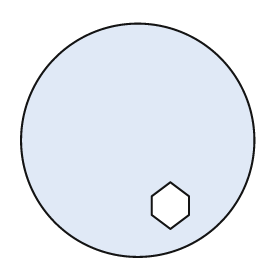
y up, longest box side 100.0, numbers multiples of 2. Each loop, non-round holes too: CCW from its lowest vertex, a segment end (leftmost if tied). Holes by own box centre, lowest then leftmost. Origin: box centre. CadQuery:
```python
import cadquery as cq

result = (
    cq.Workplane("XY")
    .moveTo(0.0, 0.0)
    .circle(50.0)
    .moveTo(14.0, -38.0)
    .lineTo(22.0, -32.0)
    .lineTo(22.0, -24.0)
    .lineTo(14.0, -18.0)
    .lineTo(6.0, -24.0)
    .lineTo(6.0, -32.0)
    .close()
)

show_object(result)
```